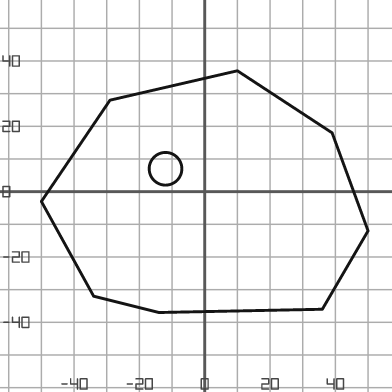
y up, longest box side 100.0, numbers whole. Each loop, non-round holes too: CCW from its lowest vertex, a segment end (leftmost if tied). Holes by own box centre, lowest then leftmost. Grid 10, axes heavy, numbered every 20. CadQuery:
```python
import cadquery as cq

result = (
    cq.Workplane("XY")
    .moveTo(-14.0, -37.0)
    .lineTo(36.0, -36.0)
    .lineTo(50.0, -12.0)
    .lineTo(39.0, 18.0)
    .lineTo(10.0, 37.0)
    .lineTo(-29.0, 28.0)
    .lineTo(-50.0, -3.0)
    .lineTo(-34.0, -32.0)
    .close()
    .moveTo(-12.0, 7.0)
    .circle(5.0)
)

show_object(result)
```